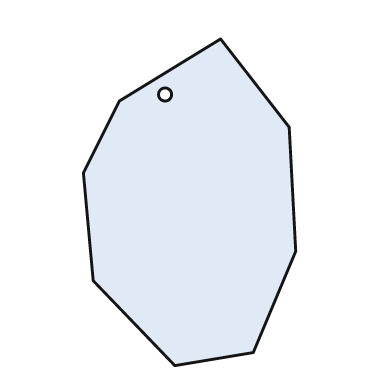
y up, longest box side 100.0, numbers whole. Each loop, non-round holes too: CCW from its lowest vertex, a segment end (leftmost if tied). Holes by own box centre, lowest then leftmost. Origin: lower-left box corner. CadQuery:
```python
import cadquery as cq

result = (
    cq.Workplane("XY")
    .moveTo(28.0, 0.0)
    .lineTo(52.0, 4.0)
    .lineTo(65.0, 35.0)
    .lineTo(63.0, 73.0)
    .lineTo(42.0, 100.0)
    .lineTo(11.0, 81.0)
    .lineTo(0.0, 59.0)
    .lineTo(3.0, 26.0)
    .close()
    .moveTo(25.0, 83.0)
    .circle(2.0)
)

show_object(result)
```